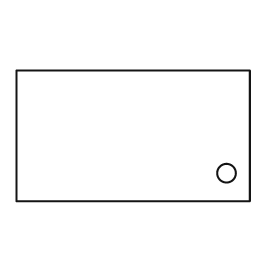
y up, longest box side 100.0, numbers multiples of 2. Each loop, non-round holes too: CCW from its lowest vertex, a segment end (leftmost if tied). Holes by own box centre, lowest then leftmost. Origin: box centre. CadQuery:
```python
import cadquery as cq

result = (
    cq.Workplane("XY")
    .moveTo(-50.0, -28.0)
    .lineTo(50.0, -28.0)
    .lineTo(50.0, 28.0)
    .lineTo(-50.0, 28.0)
    .close()
    .moveTo(40.0, -16.0)
    .circle(4.0)
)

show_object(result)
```